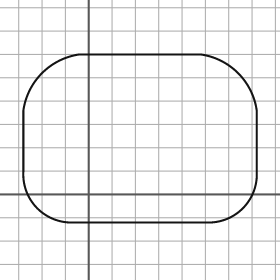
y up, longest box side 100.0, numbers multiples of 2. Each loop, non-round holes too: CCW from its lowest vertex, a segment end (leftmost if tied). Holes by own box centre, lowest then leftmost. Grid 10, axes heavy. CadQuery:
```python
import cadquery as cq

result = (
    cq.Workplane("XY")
    .moveTo(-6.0, -12.0)
    .lineTo(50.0, -12.0)
    .threePointArc((66.0, -6.0), (72.0, 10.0))
    .lineTo(72.0, 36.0)
    .threePointArc((64.0, 52.0), (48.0, 60.0))
    .lineTo(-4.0, 60.0)
    .threePointArc((-20.0, 52.0), (-28.0, 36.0))
    .lineTo(-28.0, 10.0)
    .threePointArc((-22.0, -6.0), (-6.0, -12.0))
    .close()
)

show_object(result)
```